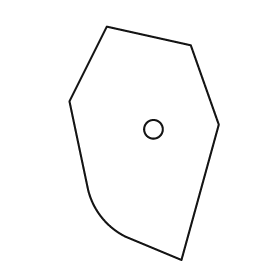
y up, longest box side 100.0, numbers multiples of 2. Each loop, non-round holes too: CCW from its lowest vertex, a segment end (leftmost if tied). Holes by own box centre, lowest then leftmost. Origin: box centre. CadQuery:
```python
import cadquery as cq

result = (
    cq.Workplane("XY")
    .moveTo(16.0, -50.0)
    .lineTo(32.0, 8.0)
    .lineTo(20.0, 42.0)
    .lineTo(-16.0, 50.0)
    .lineTo(-32.0, 18.0)
    .lineTo(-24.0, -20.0)
    .threePointArc((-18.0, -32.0), (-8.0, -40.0))
    .close()
    .moveTo(4.0, 6.0)
    .circle(4.0)
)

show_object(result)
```